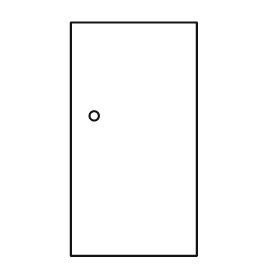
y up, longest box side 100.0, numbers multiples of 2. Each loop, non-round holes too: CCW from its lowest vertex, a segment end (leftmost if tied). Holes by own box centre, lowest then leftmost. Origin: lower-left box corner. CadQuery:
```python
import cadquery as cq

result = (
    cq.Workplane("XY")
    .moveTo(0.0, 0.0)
    .lineTo(54.0, 0.0)
    .lineTo(54.0, 100.0)
    .lineTo(0.0, 100.0)
    .close()
    .moveTo(10.0, 60.0)
    .circle(2.0)
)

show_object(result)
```